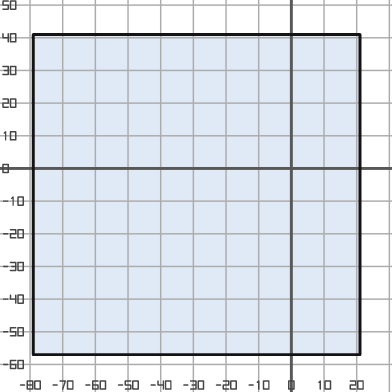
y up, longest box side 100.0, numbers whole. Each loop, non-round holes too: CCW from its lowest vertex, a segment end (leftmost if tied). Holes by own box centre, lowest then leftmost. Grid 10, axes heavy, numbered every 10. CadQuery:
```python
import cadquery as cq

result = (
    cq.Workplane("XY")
    .moveTo(-79.0, -57.0)
    .lineTo(21.0, -57.0)
    .lineTo(21.0, 41.0)
    .lineTo(-79.0, 41.0)
    .close()
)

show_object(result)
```